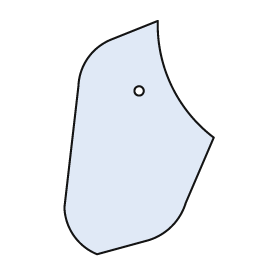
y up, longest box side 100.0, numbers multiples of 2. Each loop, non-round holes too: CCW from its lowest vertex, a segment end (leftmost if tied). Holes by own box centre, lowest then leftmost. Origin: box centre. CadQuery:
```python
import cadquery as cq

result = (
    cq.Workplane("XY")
    .moveTo(-18.0, -50.0)
    .lineTo(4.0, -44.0)
    .threePointArc((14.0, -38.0), (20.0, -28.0))
    .lineTo(32.0, 0.0)
    .threePointArc((14.0, 22.0), (8.0, 50.0))
    .lineTo(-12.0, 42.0)
    .threePointArc((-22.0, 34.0), (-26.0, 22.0))
    .lineTo(-32.0, -30.0)
    .threePointArc((-28.0, -42.0), (-18.0, -50.0))
    .close()
    .moveTo(0.0, 20.0)
    .circle(2.0)
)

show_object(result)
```